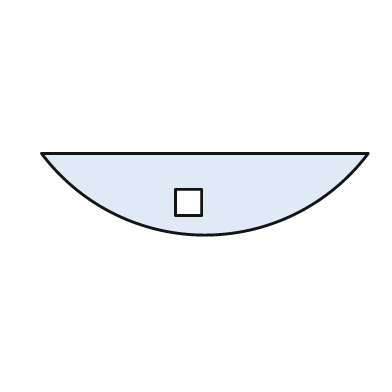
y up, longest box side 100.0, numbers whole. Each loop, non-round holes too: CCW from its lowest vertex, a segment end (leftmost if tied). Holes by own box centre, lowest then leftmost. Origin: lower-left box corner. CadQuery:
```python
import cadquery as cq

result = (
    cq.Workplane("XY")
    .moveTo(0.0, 25.0)
    .threePointArc((50.0, 0.0), (100.0, 25.0))
    .close()
    .moveTo(41.0, 6.0)
    .lineTo(49.0, 6.0)
    .lineTo(49.0, 14.0)
    .lineTo(41.0, 14.0)
    .close()
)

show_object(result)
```